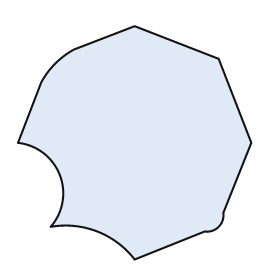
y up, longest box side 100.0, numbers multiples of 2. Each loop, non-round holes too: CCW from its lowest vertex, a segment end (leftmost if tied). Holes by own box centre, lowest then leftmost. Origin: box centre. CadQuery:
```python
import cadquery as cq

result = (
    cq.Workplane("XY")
    .moveTo(0.0, -50.0)
    .lineTo(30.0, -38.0)
    .threePointArc((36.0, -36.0), (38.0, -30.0))
    .lineTo(50.0, 0.0)
    .lineTo(36.0, 36.0)
    .lineTo(0.0, 50.0)
    .lineTo(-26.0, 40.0)
    .threePointArc((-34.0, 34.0), (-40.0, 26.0))
    .lineTo(-50.0, 0.0)
    .threePointArc((-32.0, -14.0), (-36.0, -36.0))
    .threePointArc((-16.0, -38.0), (0.0, -50.0))
    .close()
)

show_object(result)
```